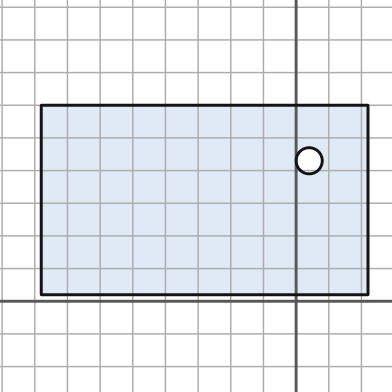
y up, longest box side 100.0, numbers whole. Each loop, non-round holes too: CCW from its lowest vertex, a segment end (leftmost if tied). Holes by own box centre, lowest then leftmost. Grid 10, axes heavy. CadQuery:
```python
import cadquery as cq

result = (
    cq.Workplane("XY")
    .moveTo(-78.0, 2.0)
    .lineTo(22.0, 2.0)
    .lineTo(22.0, 60.0)
    .lineTo(-78.0, 60.0)
    .close()
    .moveTo(4.0, 43.0)
    .circle(4.0)
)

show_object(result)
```